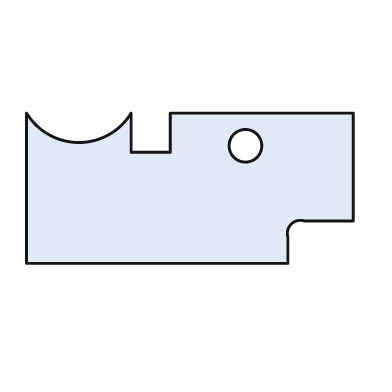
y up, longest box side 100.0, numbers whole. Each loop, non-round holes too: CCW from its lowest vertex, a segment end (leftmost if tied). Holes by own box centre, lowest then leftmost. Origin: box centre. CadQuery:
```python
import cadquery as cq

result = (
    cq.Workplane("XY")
    .moveTo(-50.0, -23.0)
    .lineTo(30.0, -23.0)
    .lineTo(30.0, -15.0)
    .threePointArc((31.0, -11.0), (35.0, -10.0))
    .lineTo(50.0, -10.0)
    .lineTo(50.0, 23.0)
    .lineTo(-6.0, 23.0)
    .lineTo(-6.0, 11.0)
    .lineTo(-18.0, 11.0)
    .lineTo(-18.0, 23.0)
    .threePointArc((-34.0, 14.0), (-50.0, 23.0))
    .close()
    .moveTo(17.0, 13.0)
    .circle(5.0)
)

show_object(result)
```